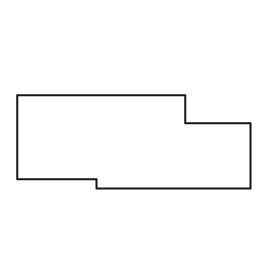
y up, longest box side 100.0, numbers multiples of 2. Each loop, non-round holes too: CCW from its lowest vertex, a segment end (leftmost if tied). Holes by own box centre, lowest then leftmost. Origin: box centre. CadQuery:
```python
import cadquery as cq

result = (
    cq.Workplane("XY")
    .moveTo(-16.0, -20.0)
    .lineTo(50.0, -20.0)
    .lineTo(50.0, 8.0)
    .lineTo(22.0, 8.0)
    .lineTo(22.0, 20.0)
    .lineTo(-50.0, 20.0)
    .lineTo(-50.0, -16.0)
    .lineTo(-16.0, -16.0)
    .close()
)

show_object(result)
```